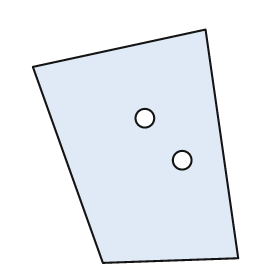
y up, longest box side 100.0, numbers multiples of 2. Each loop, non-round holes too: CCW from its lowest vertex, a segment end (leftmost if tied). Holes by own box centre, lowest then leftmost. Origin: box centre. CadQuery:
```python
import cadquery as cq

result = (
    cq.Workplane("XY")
    .moveTo(-14.0, -50.0)
    .lineTo(44.0, -48.0)
    .lineTo(30.0, 50.0)
    .lineTo(-44.0, 34.0)
    .close()
    .moveTo(20.0, -6.0)
    .circle(4.0)
    .moveTo(4.0, 12.0)
    .circle(4.0)
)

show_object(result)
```